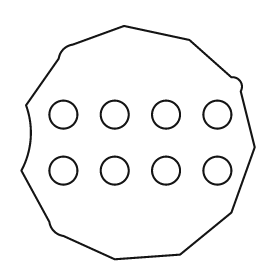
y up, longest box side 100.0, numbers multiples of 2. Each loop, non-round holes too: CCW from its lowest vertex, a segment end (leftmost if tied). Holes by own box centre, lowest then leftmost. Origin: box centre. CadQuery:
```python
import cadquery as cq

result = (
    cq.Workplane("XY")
    .moveTo(-10.0, -50.0)
    .lineTo(18.0, -48.0)
    .lineTo(40.0, -30.0)
    .lineTo(50.0, -2.0)
    .lineTo(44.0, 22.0)
    .threePointArc((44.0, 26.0), (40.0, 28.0))
    .lineTo(22.0, 44.0)
    .lineTo(-6.0, 50.0)
    .lineTo(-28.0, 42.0)
    .threePointArc((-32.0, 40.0), (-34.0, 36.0))
    .lineTo(-48.0, 16.0)
    .threePointArc((-46.0, 2.0), (-50.0, -12.0))
    .lineTo(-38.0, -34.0)
    .threePointArc((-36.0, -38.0), (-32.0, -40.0))
    .close()
    .moveTo(-32.0, -12.0)
    .circle(6.0)
    .moveTo(-10.0, -12.0)
    .circle(6.0)
    .moveTo(12.0, -12.0)
    .circle(6.0)
    .moveTo(34.0, -12.0)
    .circle(6.0)
    .moveTo(-32.0, 12.0)
    .circle(6.0)
    .moveTo(-10.0, 12.0)
    .circle(6.0)
    .moveTo(12.0, 12.0)
    .circle(6.0)
    .moveTo(34.0, 12.0)
    .circle(6.0)
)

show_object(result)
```